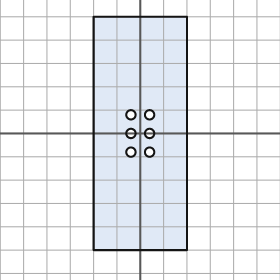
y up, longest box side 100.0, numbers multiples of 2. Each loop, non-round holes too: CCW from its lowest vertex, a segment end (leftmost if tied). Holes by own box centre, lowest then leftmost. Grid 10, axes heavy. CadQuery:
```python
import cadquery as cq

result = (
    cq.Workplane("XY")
    .moveTo(-20.0, -50.0)
    .lineTo(20.0, -50.0)
    .lineTo(20.0, 50.0)
    .lineTo(-20.0, 50.0)
    .close()
    .moveTo(-4.0, -8.0)
    .circle(2.0)
    .moveTo(4.0, -8.0)
    .circle(2.0)
    .moveTo(-4.0, 0.0)
    .circle(2.0)
    .moveTo(4.0, 0.0)
    .circle(2.0)
    .moveTo(-4.0, 8.0)
    .circle(2.0)
    .moveTo(4.0, 8.0)
    .circle(2.0)
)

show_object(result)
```